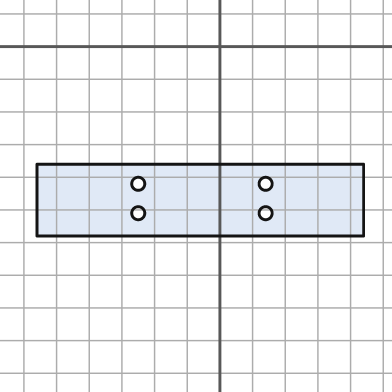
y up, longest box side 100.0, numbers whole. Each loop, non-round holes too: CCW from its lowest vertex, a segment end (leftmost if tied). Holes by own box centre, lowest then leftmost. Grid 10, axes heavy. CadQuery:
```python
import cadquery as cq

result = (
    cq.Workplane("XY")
    .moveTo(-56.0, -58.0)
    .lineTo(44.0, -58.0)
    .lineTo(44.0, -36.0)
    .lineTo(-56.0, -36.0)
    .close()
    .moveTo(-25.0, -51.0)
    .circle(2.0)
    .moveTo(14.0, -51.0)
    .circle(2.0)
    .moveTo(-25.0, -42.0)
    .circle(2.0)
    .moveTo(14.0, -42.0)
    .circle(2.0)
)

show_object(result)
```